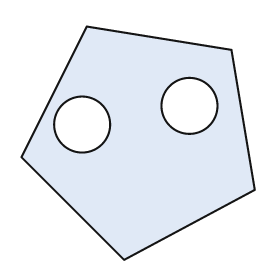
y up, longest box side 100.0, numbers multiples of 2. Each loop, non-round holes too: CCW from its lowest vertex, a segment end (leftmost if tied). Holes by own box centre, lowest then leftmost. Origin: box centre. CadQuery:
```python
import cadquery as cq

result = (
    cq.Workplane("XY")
    .moveTo(-6.0, -50.0)
    .lineTo(50.0, -20.0)
    .lineTo(40.0, 40.0)
    .lineTo(-22.0, 50.0)
    .lineTo(-50.0, -6.0)
    .close()
    .moveTo(-24.0, 8.0)
    .circle(12.0)
    .moveTo(22.0, 16.0)
    .circle(12.0)
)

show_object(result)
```